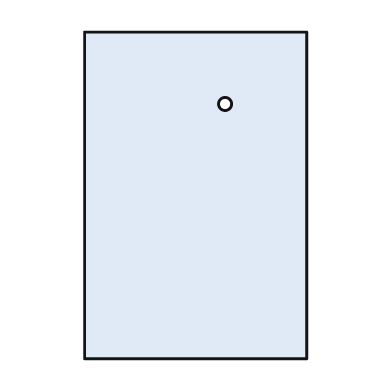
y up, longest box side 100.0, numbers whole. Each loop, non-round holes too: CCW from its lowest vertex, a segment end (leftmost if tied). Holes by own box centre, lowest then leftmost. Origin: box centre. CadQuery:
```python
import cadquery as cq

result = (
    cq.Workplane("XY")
    .moveTo(-34.0, -50.0)
    .lineTo(34.0, -50.0)
    .lineTo(34.0, 50.0)
    .lineTo(-34.0, 50.0)
    .close()
    .moveTo(9.0, 28.0)
    .circle(2.0)
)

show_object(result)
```